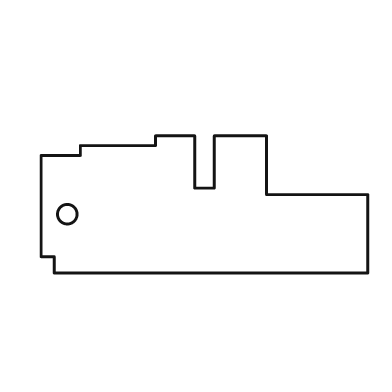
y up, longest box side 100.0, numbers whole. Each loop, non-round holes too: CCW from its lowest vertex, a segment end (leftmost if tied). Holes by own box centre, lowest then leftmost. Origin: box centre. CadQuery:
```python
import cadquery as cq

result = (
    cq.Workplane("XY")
    .moveTo(-46.0, -21.0)
    .lineTo(50.0, -21.0)
    .lineTo(50.0, 3.0)
    .lineTo(19.0, 3.0)
    .lineTo(19.0, 21.0)
    .lineTo(3.0, 21.0)
    .lineTo(3.0, 5.0)
    .lineTo(-3.0, 5.0)
    .lineTo(-3.0, 21.0)
    .lineTo(-15.0, 21.0)
    .lineTo(-15.0, 18.0)
    .lineTo(-38.0, 18.0)
    .lineTo(-38.0, 15.0)
    .lineTo(-50.0, 15.0)
    .lineTo(-50.0, -16.0)
    .lineTo(-46.0, -16.0)
    .close()
    .moveTo(-42.0, -3.0)
    .circle(3.0)
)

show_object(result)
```